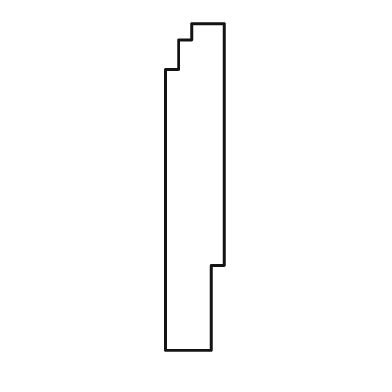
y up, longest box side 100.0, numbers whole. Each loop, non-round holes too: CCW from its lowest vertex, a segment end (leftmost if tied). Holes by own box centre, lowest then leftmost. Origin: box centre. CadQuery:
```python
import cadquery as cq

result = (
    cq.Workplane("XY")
    .moveTo(-9.0, -50.0)
    .lineTo(5.0, -50.0)
    .lineTo(5.0, -24.0)
    .lineTo(9.0, -24.0)
    .lineTo(9.0, 50.0)
    .lineTo(-1.0, 50.0)
    .lineTo(-1.0, 45.0)
    .lineTo(-5.0, 45.0)
    .lineTo(-5.0, 36.0)
    .lineTo(-9.0, 36.0)
    .close()
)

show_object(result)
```